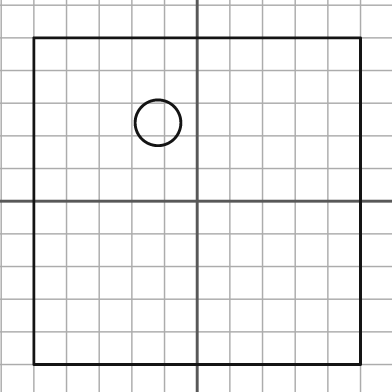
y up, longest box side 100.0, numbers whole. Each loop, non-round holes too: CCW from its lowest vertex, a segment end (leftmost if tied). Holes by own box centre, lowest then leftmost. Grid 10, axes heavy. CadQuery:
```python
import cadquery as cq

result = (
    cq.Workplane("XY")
    .moveTo(-50.0, -50.0)
    .lineTo(50.0, -50.0)
    .lineTo(50.0, 50.0)
    .lineTo(-50.0, 50.0)
    .close()
    .moveTo(-12.0, 24.0)
    .circle(7.0)
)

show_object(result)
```